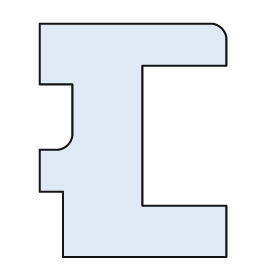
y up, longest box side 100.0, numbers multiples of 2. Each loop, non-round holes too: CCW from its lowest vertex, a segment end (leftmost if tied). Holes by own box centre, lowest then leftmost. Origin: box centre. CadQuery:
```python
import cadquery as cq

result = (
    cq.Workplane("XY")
    .moveTo(-30.0, -50.0)
    .lineTo(40.0, -50.0)
    .lineTo(40.0, -28.0)
    .lineTo(4.0, -28.0)
    .lineTo(4.0, 32.0)
    .lineTo(40.0, 32.0)
    .lineTo(40.0, 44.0)
    .threePointArc((38.0, 48.0), (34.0, 50.0))
    .lineTo(-40.0, 50.0)
    .lineTo(-40.0, 24.0)
    .lineTo(-26.0, 24.0)
    .lineTo(-26.0, 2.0)
    .threePointArc((-28.0, -2.0), (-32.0, -4.0))
    .lineTo(-40.0, -4.0)
    .lineTo(-40.0, -22.0)
    .lineTo(-30.0, -22.0)
    .close()
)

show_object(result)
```